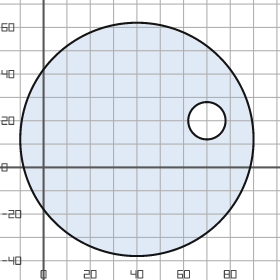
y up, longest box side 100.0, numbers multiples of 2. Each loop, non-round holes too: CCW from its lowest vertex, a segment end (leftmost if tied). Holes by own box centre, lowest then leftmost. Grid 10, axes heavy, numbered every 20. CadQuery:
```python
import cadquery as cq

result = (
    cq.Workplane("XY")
    .moveTo(40.0, 12.0)
    .circle(50.0)
    .moveTo(70.0, 20.0)
    .circle(8.0)
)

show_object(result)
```